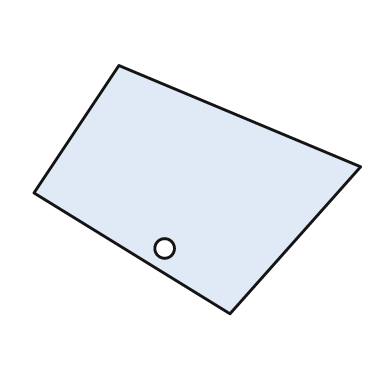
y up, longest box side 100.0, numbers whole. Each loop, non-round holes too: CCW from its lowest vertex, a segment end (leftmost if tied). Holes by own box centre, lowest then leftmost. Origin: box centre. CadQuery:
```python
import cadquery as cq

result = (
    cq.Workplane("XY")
    .moveTo(10.0, -38.0)
    .lineTo(50.0, 7.0)
    .lineTo(-24.0, 38.0)
    .lineTo(-50.0, -1.0)
    .close()
    .moveTo(-10.0, -18.0)
    .circle(3.0)
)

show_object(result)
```